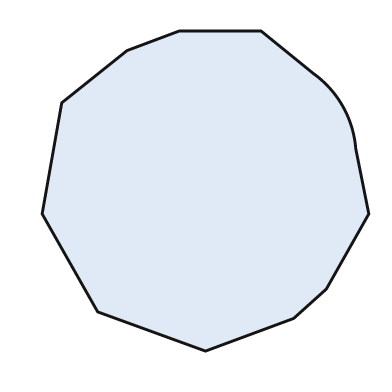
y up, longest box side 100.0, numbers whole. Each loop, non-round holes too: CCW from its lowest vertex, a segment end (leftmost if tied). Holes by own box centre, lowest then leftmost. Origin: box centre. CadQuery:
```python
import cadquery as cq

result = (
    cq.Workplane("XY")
    .moveTo(0.0, -49.0)
    .lineTo(27.0, -39.0)
    .lineTo(37.0, -30.0)
    .lineTo(50.0, -7.0)
    .lineTo(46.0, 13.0)
    .threePointArc((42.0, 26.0), (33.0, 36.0))
    .lineTo(17.0, 49.0)
    .lineTo(-8.0, 49.0)
    .lineTo(-24.0, 43.0)
    .lineTo(-44.0, 27.0)
    .lineTo(-50.0, -7.0)
    .lineTo(-33.0, -37.0)
    .close()
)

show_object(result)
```